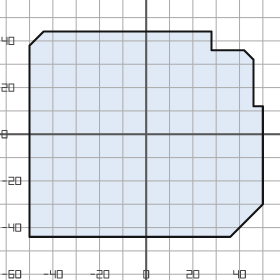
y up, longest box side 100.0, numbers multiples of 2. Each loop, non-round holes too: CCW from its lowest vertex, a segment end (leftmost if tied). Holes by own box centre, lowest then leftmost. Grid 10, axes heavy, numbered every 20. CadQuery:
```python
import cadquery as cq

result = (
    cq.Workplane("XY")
    .moveTo(-50.0, -44.0)
    .lineTo(36.0, -44.0)
    .lineTo(50.0, -30.0)
    .lineTo(50.0, 12.0)
    .lineTo(46.0, 12.0)
    .lineTo(46.0, 32.0)
    .lineTo(42.0, 36.0)
    .lineTo(28.0, 36.0)
    .lineTo(28.0, 44.0)
    .lineTo(-44.0, 44.0)
    .lineTo(-50.0, 38.0)
    .close()
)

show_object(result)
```